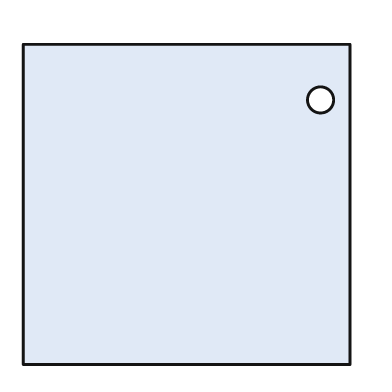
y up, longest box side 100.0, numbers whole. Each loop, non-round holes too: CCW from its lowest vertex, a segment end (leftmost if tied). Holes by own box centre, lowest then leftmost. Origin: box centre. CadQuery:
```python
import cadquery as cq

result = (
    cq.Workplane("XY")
    .moveTo(-50.0, -49.0)
    .lineTo(50.0, -49.0)
    .lineTo(50.0, 49.0)
    .lineTo(-50.0, 49.0)
    .close()
    .moveTo(41.0, 32.0)
    .circle(4.0)
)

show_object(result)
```